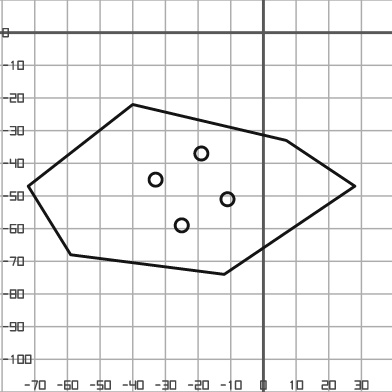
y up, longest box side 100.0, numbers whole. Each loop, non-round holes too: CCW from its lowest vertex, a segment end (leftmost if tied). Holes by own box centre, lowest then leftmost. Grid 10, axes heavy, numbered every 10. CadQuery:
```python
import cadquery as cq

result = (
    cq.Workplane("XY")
    .moveTo(-12.0, -74.0)
    .lineTo(28.0, -47.0)
    .lineTo(7.0, -33.0)
    .lineTo(-40.0, -22.0)
    .lineTo(-72.0, -47.0)
    .lineTo(-59.0, -68.0)
    .close()
    .moveTo(-25.0, -59.0)
    .circle(2.0)
    .moveTo(-11.0, -51.0)
    .circle(2.0)
    .moveTo(-33.0, -45.0)
    .circle(2.0)
    .moveTo(-19.0, -37.0)
    .circle(2.0)
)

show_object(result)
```